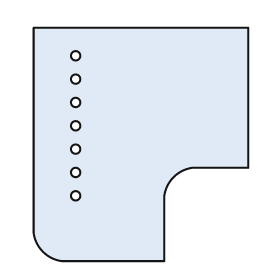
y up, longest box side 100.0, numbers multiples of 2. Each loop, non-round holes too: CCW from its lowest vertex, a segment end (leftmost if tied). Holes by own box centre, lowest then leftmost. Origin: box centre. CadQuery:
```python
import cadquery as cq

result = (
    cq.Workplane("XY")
    .moveTo(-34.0, -50.0)
    .lineTo(10.0, -50.0)
    .lineTo(10.0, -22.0)
    .threePointArc((14.0, -14.0), (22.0, -10.0))
    .lineTo(46.0, -10.0)
    .lineTo(46.0, 50.0)
    .lineTo(-46.0, 50.0)
    .lineTo(-46.0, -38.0)
    .threePointArc((-42.0, -46.0), (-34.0, -50.0))
    .close()
    .moveTo(-28.0, -22.0)
    .circle(2.0)
    .moveTo(-28.0, -12.0)
    .circle(2.0)
    .moveTo(-28.0, -2.0)
    .circle(2.0)
    .moveTo(-28.0, 8.0)
    .circle(2.0)
    .moveTo(-28.0, 18.0)
    .circle(2.0)
    .moveTo(-28.0, 28.0)
    .circle(2.0)
    .moveTo(-28.0, 38.0)
    .circle(2.0)
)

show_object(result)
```